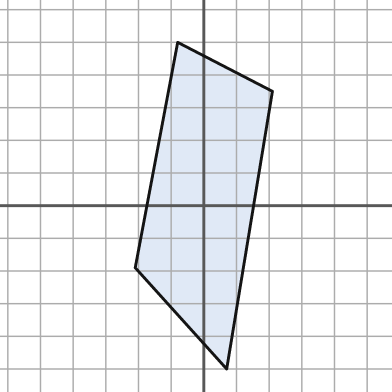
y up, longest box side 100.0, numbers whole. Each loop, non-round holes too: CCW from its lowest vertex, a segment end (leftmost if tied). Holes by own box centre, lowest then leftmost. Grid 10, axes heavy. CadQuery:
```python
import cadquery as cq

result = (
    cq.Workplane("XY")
    .moveTo(7.0, -50.0)
    .lineTo(21.0, 35.0)
    .lineTo(-8.0, 50.0)
    .lineTo(-21.0, -19.0)
    .close()
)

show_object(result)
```